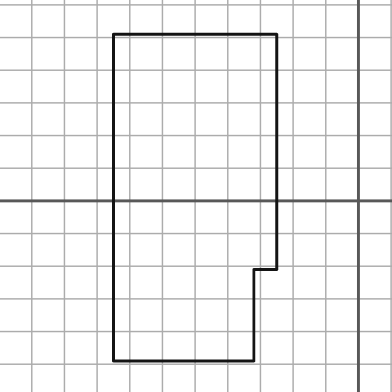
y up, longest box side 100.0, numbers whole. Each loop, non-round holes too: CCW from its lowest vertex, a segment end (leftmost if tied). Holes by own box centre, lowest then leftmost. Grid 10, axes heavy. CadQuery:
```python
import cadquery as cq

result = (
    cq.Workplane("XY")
    .moveTo(-75.0, -49.0)
    .lineTo(-32.0, -49.0)
    .lineTo(-32.0, -21.0)
    .lineTo(-25.0, -21.0)
    .lineTo(-25.0, 51.0)
    .lineTo(-75.0, 51.0)
    .close()
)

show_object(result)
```